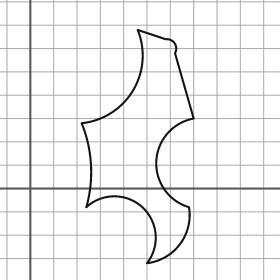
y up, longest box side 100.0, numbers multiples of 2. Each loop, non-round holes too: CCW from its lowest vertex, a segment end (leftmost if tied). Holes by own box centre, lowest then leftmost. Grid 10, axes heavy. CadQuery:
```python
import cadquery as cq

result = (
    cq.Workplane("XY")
    .moveTo(50.0, -32.0)
    .threePointArc((64.0, -24.0), (68.0, -8.0))
    .threePointArc((54.0, 12.0), (70.0, 30.0))
    .lineTo(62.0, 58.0)
    .threePointArc((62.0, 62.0), (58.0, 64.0))
    .lineTo(46.0, 68.0)
    .threePointArc((44.0, 42.0), (22.0, 28.0))
    .threePointArc((26.0, 10.0), (24.0, -8.0))
    .threePointArc((48.0, -8.0), (50.0, -32.0))
    .close()
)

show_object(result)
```